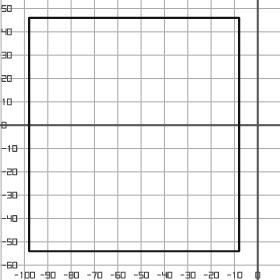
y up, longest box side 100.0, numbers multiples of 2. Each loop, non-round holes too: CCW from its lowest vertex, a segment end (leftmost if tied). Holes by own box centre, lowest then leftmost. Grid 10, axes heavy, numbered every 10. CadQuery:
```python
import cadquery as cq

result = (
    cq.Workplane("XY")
    .moveTo(-98.0, -54.0)
    .lineTo(-8.0, -54.0)
    .lineTo(-8.0, 46.0)
    .lineTo(-98.0, 46.0)
    .close()
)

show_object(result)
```